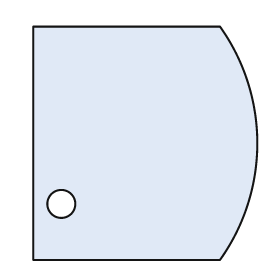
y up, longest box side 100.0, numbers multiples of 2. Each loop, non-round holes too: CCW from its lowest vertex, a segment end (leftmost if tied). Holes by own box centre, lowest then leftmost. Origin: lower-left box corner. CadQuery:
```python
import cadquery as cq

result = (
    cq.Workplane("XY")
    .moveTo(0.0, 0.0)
    .lineTo(80.0, 0.0)
    .threePointArc((96.0, 50.0), (80.0, 100.0))
    .lineTo(0.0, 100.0)
    .close()
    .moveTo(12.0, 24.0)
    .circle(6.0)
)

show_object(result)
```